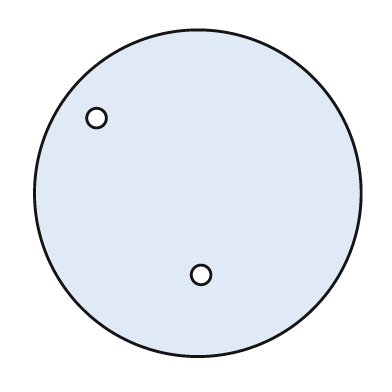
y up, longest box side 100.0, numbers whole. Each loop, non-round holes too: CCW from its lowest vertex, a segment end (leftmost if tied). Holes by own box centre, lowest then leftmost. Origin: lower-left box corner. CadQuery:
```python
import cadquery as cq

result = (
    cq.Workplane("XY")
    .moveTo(50.0, 50.0)
    .circle(50.0)
    .moveTo(51.0, 25.0)
    .circle(3.0)
    .moveTo(19.0, 73.0)
    .circle(3.0)
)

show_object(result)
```